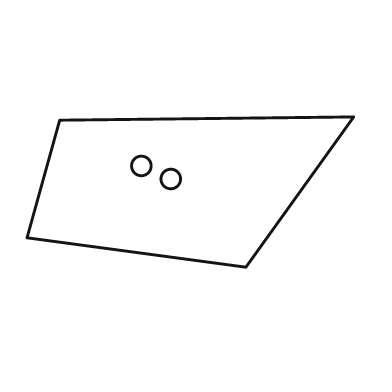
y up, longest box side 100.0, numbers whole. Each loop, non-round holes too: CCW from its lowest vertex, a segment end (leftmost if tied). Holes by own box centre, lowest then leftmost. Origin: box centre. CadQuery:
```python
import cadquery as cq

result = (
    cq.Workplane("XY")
    .moveTo(17.0, -23.0)
    .lineTo(50.0, 23.0)
    .lineTo(-40.0, 22.0)
    .lineTo(-50.0, -14.0)
    .close()
    .moveTo(-6.0, 4.0)
    .circle(3.0)
    .moveTo(-15.0, 8.0)
    .circle(3.0)
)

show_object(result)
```